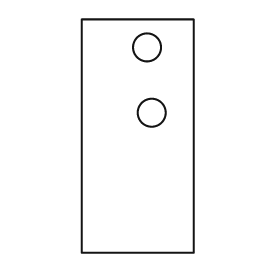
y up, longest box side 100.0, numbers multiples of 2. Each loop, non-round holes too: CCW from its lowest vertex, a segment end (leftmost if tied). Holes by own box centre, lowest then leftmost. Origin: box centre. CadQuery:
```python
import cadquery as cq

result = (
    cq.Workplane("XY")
    .moveTo(-24.0, -50.0)
    .lineTo(24.0, -50.0)
    .lineTo(24.0, 50.0)
    .lineTo(-24.0, 50.0)
    .close()
    .moveTo(6.0, 10.0)
    .circle(6.0)
    .moveTo(4.0, 38.0)
    .circle(6.0)
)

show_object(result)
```